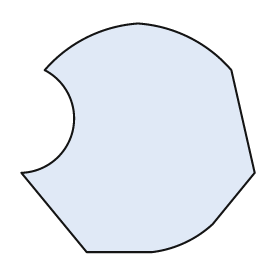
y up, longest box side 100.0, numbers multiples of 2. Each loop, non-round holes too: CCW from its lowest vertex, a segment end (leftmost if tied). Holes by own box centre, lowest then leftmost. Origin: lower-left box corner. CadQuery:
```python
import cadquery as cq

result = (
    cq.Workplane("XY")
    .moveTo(28.0, 0.0)
    .lineTo(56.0, 0.0)
    .threePointArc((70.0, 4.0), (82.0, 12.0))
    .lineTo(100.0, 34.0)
    .lineTo(90.0, 78.0)
    .threePointArc((72.0, 92.0), (50.0, 98.0))
    .threePointArc((28.0, 92.0), (10.0, 78.0))
    .threePointArc((22.0, 52.0), (0.0, 34.0))
    .close()
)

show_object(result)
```